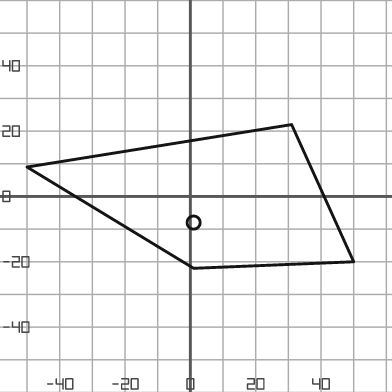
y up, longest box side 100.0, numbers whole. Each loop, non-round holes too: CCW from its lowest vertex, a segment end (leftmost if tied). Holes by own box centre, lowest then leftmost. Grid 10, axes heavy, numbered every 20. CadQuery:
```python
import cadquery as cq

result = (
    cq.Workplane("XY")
    .moveTo(1.0, -22.0)
    .lineTo(50.0, -20.0)
    .lineTo(31.0, 22.0)
    .lineTo(-50.0, 9.0)
    .close()
    .moveTo(1.0, -8.0)
    .circle(2.0)
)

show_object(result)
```